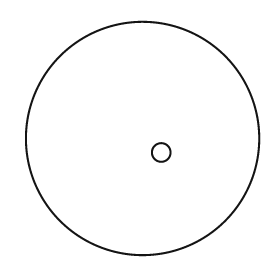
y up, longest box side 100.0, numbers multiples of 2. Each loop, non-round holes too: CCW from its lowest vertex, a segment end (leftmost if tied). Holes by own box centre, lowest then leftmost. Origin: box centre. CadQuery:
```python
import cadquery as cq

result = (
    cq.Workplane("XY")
    .moveTo(0.0, 0.0)
    .circle(50.0)
    .moveTo(8.0, -6.0)
    .circle(4.0)
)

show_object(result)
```